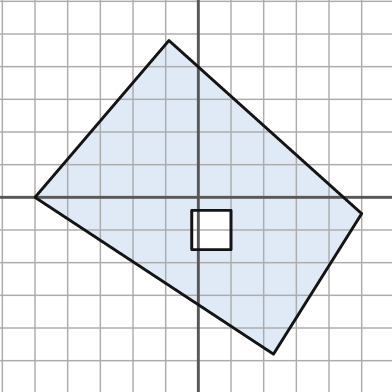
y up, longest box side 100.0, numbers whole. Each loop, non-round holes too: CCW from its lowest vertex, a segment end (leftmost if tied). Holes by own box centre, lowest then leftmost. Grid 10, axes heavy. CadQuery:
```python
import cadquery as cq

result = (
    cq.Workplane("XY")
    .moveTo(23.0, -48.0)
    .lineTo(50.0, -5.0)
    .lineTo(-9.0, 48.0)
    .lineTo(-50.0, 0.0)
    .close()
    .moveTo(-2.0, -16.0)
    .lineTo(10.0, -16.0)
    .lineTo(10.0, -4.0)
    .lineTo(-2.0, -4.0)
    .close()
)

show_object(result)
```